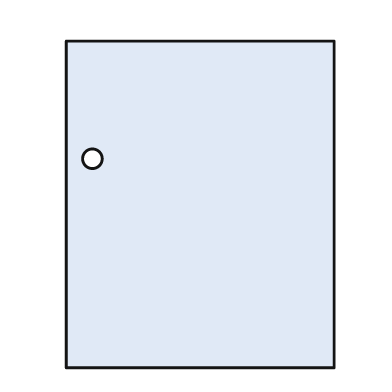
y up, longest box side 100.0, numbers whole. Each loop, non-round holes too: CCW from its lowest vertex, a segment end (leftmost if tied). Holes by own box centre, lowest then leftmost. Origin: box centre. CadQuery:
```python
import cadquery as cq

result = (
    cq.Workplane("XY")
    .moveTo(-41.0, -50.0)
    .lineTo(41.0, -50.0)
    .lineTo(41.0, 50.0)
    .lineTo(-41.0, 50.0)
    .close()
    .moveTo(-33.0, 14.0)
    .circle(3.0)
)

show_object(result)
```